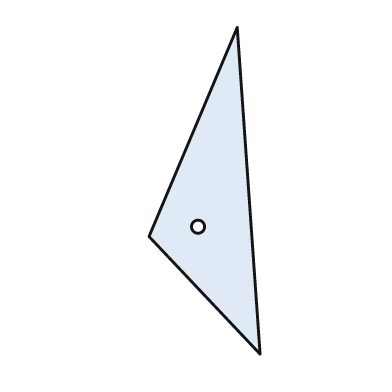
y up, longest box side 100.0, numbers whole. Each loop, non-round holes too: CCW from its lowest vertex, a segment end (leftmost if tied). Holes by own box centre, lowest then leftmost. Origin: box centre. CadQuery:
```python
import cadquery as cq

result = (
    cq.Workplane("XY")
    .moveTo(17.0, -50.0)
    .lineTo(10.0, 50.0)
    .lineTo(-17.0, -14.0)
    .close()
    .moveTo(-2.0, -11.0)
    .circle(2.0)
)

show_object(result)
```